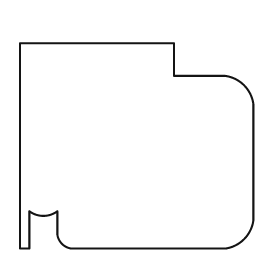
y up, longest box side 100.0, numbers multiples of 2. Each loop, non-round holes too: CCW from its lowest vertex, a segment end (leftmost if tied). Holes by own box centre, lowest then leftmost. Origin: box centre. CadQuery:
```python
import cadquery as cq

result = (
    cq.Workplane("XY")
    .moveTo(-50.0, -44.0)
    .lineTo(-46.0, -44.0)
    .lineTo(-46.0, -28.0)
    .threePointArc((-40.0, -30.0), (-34.0, -28.0))
    .lineTo(-34.0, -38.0)
    .threePointArc((-32.0, -42.0), (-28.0, -44.0))
    .lineTo(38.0, -44.0)
    .threePointArc((46.0, -40.0), (50.0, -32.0))
    .lineTo(50.0, 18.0)
    .threePointArc((46.0, 26.0), (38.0, 30.0))
    .lineTo(16.0, 30.0)
    .lineTo(16.0, 44.0)
    .lineTo(-50.0, 44.0)
    .close()
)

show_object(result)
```